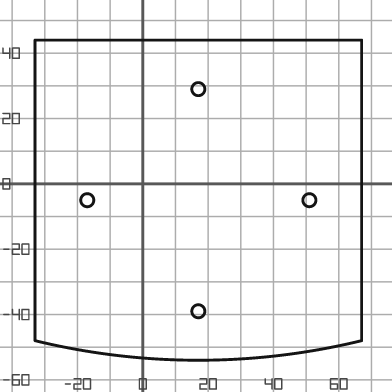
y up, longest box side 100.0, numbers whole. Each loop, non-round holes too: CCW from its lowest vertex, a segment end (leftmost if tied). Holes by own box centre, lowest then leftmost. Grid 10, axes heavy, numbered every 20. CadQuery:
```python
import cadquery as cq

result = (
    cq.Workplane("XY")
    .moveTo(-33.0, -48.0)
    .threePointArc((17.0, -54.0), (67.0, -48.0))
    .lineTo(67.0, 44.0)
    .lineTo(-33.0, 44.0)
    .close()
    .moveTo(17.0, -39.0)
    .circle(2.0)
    .moveTo(-17.0, -5.0)
    .circle(2.0)
    .moveTo(51.0, -5.0)
    .circle(2.0)
    .moveTo(17.0, 29.0)
    .circle(2.0)
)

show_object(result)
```